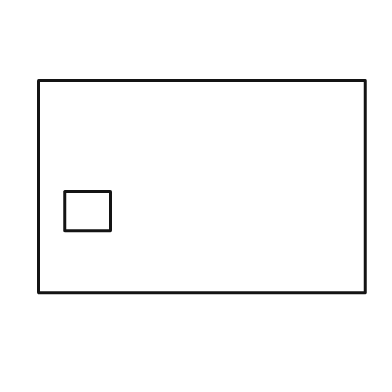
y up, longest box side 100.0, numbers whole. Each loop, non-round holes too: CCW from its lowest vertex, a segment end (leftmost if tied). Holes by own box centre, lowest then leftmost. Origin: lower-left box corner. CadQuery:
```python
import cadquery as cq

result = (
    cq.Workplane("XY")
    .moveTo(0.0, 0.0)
    .lineTo(100.0, 0.0)
    .lineTo(100.0, 65.0)
    .lineTo(0.0, 65.0)
    .close()
    .moveTo(8.0, 19.0)
    .lineTo(22.0, 19.0)
    .lineTo(22.0, 31.0)
    .lineTo(8.0, 31.0)
    .close()
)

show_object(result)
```